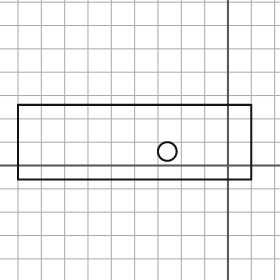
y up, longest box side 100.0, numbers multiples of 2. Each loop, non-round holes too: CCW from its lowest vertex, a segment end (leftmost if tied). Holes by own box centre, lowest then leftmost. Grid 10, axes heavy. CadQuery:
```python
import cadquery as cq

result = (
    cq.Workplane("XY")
    .moveTo(-90.0, -6.0)
    .lineTo(10.0, -6.0)
    .lineTo(10.0, 26.0)
    .lineTo(-90.0, 26.0)
    .close()
    .moveTo(-26.0, 6.0)
    .circle(4.0)
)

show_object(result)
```